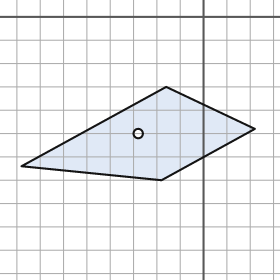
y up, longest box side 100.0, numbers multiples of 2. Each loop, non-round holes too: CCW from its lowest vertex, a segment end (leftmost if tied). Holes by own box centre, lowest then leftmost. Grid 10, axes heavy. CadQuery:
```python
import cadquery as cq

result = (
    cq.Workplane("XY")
    .moveTo(-18.0, -70.0)
    .lineTo(22.0, -48.0)
    .lineTo(-16.0, -30.0)
    .lineTo(-78.0, -64.0)
    .close()
    .moveTo(-28.0, -50.0)
    .circle(2.0)
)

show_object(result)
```